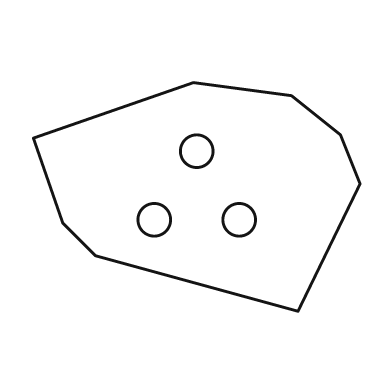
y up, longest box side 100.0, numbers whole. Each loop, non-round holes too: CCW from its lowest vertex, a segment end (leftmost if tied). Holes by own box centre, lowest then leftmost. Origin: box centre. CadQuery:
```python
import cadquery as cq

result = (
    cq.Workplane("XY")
    .moveTo(31.0, -35.0)
    .lineTo(50.0, 4.0)
    .lineTo(44.0, 19.0)
    .lineTo(29.0, 31.0)
    .lineTo(-1.0, 35.0)
    .lineTo(-50.0, 18.0)
    .lineTo(-41.0, -8.0)
    .lineTo(-31.0, -18.0)
    .close()
    .moveTo(-13.0, -7.0)
    .circle(5.0)
    .moveTo(13.0, -7.0)
    .circle(5.0)
    .moveTo(0.0, 14.0)
    .circle(5.0)
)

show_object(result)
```